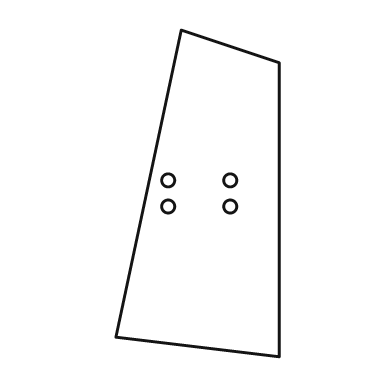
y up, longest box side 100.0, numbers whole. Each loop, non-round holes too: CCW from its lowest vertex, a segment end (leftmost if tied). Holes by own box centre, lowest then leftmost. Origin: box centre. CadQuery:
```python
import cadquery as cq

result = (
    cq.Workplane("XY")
    .moveTo(25.0, -50.0)
    .lineTo(25.0, 40.0)
    .lineTo(-5.0, 50.0)
    .lineTo(-25.0, -44.0)
    .close()
    .moveTo(-9.0, -4.0)
    .circle(2.0)
    .moveTo(10.0, -4.0)
    .circle(2.0)
    .moveTo(-9.0, 4.0)
    .circle(2.0)
    .moveTo(10.0, 4.0)
    .circle(2.0)
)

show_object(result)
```